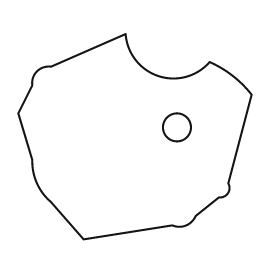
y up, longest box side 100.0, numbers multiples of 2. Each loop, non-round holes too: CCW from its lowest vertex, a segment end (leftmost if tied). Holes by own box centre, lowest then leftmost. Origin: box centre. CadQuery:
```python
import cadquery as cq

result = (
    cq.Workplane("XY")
    .moveTo(-22.0, -44.0)
    .lineTo(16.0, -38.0)
    .threePointArc((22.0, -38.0), (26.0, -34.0))
    .lineTo(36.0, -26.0)
    .threePointArc((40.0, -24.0), (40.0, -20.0))
    .lineTo(50.0, 18.0)
    .threePointArc((42.0, 26.0), (32.0, 32.0))
    .threePointArc((10.0, 26.0), (-4.0, 44.0))
    .lineTo(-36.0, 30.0)
    .threePointArc((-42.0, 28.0), (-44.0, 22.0))
    .lineTo(-50.0, 10.0)
    .lineTo(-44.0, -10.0)
    .threePointArc((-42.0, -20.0), (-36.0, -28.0))
    .close()
    .moveTo(18.0, 4.0)
    .circle(6.0)
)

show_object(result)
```